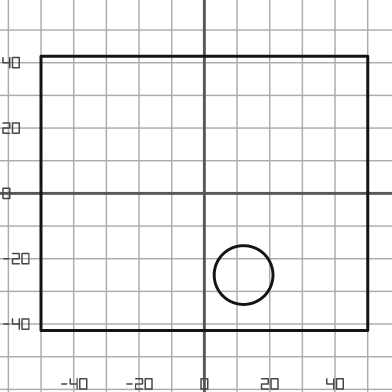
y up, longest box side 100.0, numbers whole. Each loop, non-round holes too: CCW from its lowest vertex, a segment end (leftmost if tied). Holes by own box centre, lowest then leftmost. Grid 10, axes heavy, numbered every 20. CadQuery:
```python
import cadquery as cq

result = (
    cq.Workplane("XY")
    .moveTo(-50.0, -42.0)
    .lineTo(50.0, -42.0)
    .lineTo(50.0, 42.0)
    .lineTo(-50.0, 42.0)
    .close()
    .moveTo(12.0, -25.0)
    .circle(9.0)
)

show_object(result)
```